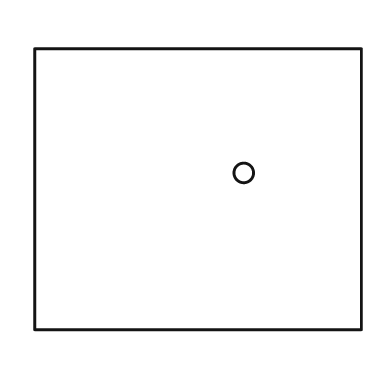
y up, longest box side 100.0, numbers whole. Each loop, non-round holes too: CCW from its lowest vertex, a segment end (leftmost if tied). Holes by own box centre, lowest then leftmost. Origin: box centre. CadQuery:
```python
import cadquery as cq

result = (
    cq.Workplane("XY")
    .moveTo(-50.0, -43.0)
    .lineTo(50.0, -43.0)
    .lineTo(50.0, 43.0)
    .lineTo(-50.0, 43.0)
    .close()
    .moveTo(14.0, 5.0)
    .circle(3.0)
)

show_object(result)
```